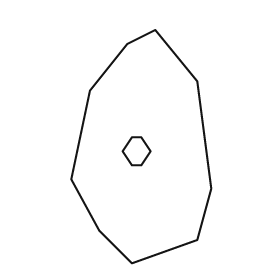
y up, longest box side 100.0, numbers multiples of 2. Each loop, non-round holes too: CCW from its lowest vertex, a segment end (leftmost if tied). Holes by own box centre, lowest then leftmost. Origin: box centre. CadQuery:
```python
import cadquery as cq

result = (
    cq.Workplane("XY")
    .moveTo(-4.0, -50.0)
    .lineTo(24.0, -40.0)
    .lineTo(30.0, -18.0)
    .lineTo(24.0, 28.0)
    .lineTo(6.0, 50.0)
    .lineTo(-6.0, 44.0)
    .lineTo(-22.0, 24.0)
    .lineTo(-30.0, -14.0)
    .lineTo(-18.0, -36.0)
    .close()
    .moveTo(-4.0, -8.0)
    .lineTo(0.0, -8.0)
    .lineTo(4.0, -2.0)
    .lineTo(0.0, 4.0)
    .lineTo(-4.0, 4.0)
    .lineTo(-8.0, -2.0)
    .close()
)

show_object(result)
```